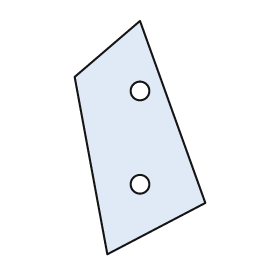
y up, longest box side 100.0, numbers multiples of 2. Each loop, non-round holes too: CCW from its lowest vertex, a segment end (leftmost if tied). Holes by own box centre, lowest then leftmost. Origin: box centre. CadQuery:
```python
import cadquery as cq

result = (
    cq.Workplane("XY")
    .moveTo(-14.0, -50.0)
    .lineTo(28.0, -28.0)
    .lineTo(0.0, 50.0)
    .lineTo(-28.0, 26.0)
    .close()
    .moveTo(0.0, -20.0)
    .circle(4.0)
    .moveTo(0.0, 20.0)
    .circle(4.0)
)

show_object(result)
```